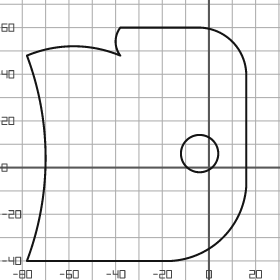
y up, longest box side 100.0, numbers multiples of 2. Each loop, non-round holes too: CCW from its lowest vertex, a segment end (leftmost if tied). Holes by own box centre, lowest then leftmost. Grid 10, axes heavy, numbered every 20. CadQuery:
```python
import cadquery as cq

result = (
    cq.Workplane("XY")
    .moveTo(-78.0, -40.0)
    .lineTo(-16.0, -40.0)
    .threePointArc((6.0, -30.0), (16.0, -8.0))
    .lineTo(16.0, 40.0)
    .threePointArc((10.0, 54.0), (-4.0, 60.0))
    .lineTo(-38.0, 60.0)
    .threePointArc((-40.0, 54.0), (-38.0, 48.0))
    .threePointArc((-58.0, 52.0), (-78.0, 48.0))
    .threePointArc((-70.0, 4.0), (-78.0, -40.0))
    .close()
    .moveTo(-4.0, 6.0)
    .circle(8.0)
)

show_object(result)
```